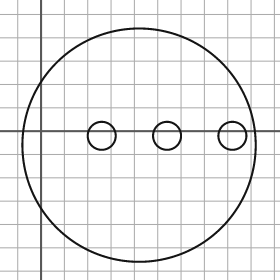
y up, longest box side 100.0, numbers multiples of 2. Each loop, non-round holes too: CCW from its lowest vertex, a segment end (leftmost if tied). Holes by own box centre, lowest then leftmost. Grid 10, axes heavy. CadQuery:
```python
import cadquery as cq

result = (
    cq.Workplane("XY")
    .moveTo(42.0, -6.0)
    .circle(50.0)
    .moveTo(26.0, -2.0)
    .circle(6.0)
    .moveTo(54.0, -2.0)
    .circle(6.0)
    .moveTo(82.0, -2.0)
    .circle(6.0)
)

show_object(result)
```